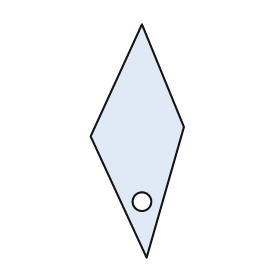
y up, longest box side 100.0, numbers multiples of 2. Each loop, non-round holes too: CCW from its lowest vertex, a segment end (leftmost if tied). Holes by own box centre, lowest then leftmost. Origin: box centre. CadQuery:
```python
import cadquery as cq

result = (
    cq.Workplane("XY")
    .moveTo(4.0, -50.0)
    .lineTo(20.0, 6.0)
    .lineTo(2.0, 50.0)
    .lineTo(-20.0, 2.0)
    .close()
    .moveTo(2.0, -26.0)
    .circle(4.0)
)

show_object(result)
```